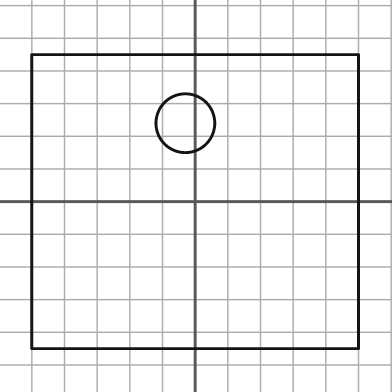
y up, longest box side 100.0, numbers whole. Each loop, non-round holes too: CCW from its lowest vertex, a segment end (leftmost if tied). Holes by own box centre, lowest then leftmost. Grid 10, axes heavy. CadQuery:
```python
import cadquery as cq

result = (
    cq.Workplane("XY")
    .moveTo(-50.0, -45.0)
    .lineTo(50.0, -45.0)
    .lineTo(50.0, 45.0)
    .lineTo(-50.0, 45.0)
    .close()
    .moveTo(-3.0, 24.0)
    .circle(9.0)
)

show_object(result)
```